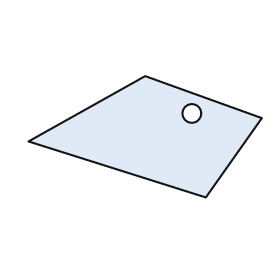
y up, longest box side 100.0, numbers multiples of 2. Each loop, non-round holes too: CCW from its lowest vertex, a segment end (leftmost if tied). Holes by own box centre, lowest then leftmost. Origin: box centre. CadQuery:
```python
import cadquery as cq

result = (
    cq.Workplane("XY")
    .moveTo(26.0, -26.0)
    .lineTo(50.0, 8.0)
    .lineTo(0.0, 26.0)
    .lineTo(-50.0, -2.0)
    .close()
    .moveTo(20.0, 10.0)
    .circle(4.0)
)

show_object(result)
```